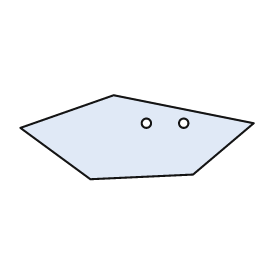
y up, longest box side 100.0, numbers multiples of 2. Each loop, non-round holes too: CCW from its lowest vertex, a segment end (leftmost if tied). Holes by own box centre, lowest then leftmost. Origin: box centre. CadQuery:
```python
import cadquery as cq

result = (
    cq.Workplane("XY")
    .moveTo(-20.0, -18.0)
    .lineTo(24.0, -16.0)
    .lineTo(50.0, 6.0)
    .lineTo(-10.0, 18.0)
    .lineTo(-50.0, 4.0)
    .close()
    .moveTo(4.0, 6.0)
    .circle(2.0)
    .moveTo(20.0, 6.0)
    .circle(2.0)
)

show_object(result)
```